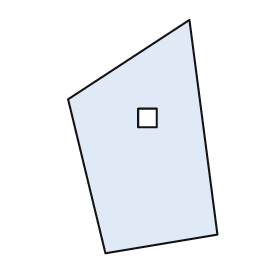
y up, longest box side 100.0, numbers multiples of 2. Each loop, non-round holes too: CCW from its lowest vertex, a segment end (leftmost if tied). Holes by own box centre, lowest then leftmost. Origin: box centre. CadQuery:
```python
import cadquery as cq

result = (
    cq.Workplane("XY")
    .moveTo(-16.0, -50.0)
    .lineTo(32.0, -42.0)
    .lineTo(20.0, 50.0)
    .lineTo(-32.0, 16.0)
    .close()
    .moveTo(-2.0, 4.0)
    .lineTo(6.0, 4.0)
    .lineTo(6.0, 12.0)
    .lineTo(-2.0, 12.0)
    .close()
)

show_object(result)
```